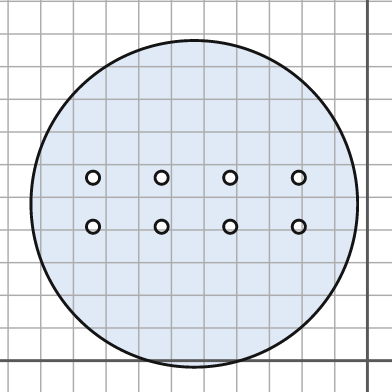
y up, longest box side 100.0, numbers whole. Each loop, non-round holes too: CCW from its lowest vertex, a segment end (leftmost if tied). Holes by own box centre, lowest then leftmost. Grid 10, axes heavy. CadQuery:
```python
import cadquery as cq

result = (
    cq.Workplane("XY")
    .moveTo(-53.0, 48.0)
    .circle(50.0)
    .moveTo(-84.0, 41.0)
    .circle(2.0)
    .moveTo(-63.0, 41.0)
    .circle(2.0)
    .moveTo(-42.0, 41.0)
    .circle(2.0)
    .moveTo(-21.0, 41.0)
    .circle(2.0)
    .moveTo(-84.0, 56.0)
    .circle(2.0)
    .moveTo(-63.0, 56.0)
    .circle(2.0)
    .moveTo(-42.0, 56.0)
    .circle(2.0)
    .moveTo(-21.0, 56.0)
    .circle(2.0)
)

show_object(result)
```